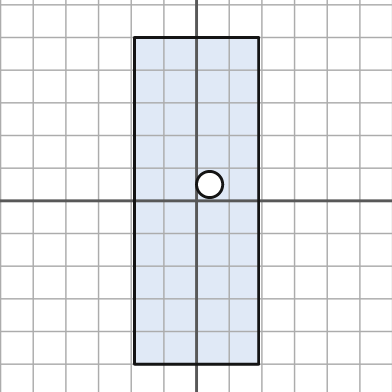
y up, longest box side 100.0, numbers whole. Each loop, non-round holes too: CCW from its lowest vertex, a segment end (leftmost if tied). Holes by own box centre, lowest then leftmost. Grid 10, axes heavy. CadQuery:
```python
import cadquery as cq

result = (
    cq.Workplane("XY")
    .moveTo(-19.0, -50.0)
    .lineTo(19.0, -50.0)
    .lineTo(19.0, 50.0)
    .lineTo(-19.0, 50.0)
    .close()
    .moveTo(4.0, 5.0)
    .circle(4.0)
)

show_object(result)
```